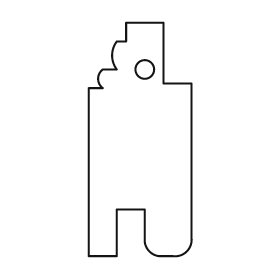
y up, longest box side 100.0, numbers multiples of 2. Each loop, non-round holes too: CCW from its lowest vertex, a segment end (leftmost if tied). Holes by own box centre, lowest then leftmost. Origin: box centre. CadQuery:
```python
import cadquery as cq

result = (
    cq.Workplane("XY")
    .moveTo(-22.0, -50.0)
    .lineTo(-10.0, -50.0)
    .lineTo(-10.0, -30.0)
    .lineTo(2.0, -30.0)
    .lineTo(2.0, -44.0)
    .threePointArc((4.0, -48.0), (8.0, -50.0))
    .lineTo(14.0, -50.0)
    .threePointArc((20.0, -48.0), (22.0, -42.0))
    .lineTo(22.0, 24.0)
    .lineTo(10.0, 24.0)
    .lineTo(10.0, 50.0)
    .lineTo(-6.0, 50.0)
    .lineTo(-6.0, 42.0)
    .lineTo(-10.0, 42.0)
    .threePointArc((-12.0, 36.0), (-10.0, 30.0))
    .lineTo(-16.0, 30.0)
    .threePointArc((-18.0, 26.0), (-16.0, 22.0))
    .lineTo(-22.0, 22.0)
    .close()
    .moveTo(2.0, 30.0)
    .circle(4.0)
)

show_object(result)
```